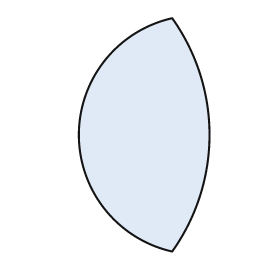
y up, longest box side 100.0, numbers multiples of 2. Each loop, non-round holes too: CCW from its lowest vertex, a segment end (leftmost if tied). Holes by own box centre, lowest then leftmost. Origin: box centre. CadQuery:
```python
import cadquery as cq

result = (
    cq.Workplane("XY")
    .moveTo(12.0, -50.0)
    .threePointArc((28.0, 0.0), (12.0, 50.0))
    .threePointArc((-28.0, 0.0), (12.0, -50.0))
    .close()
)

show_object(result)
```